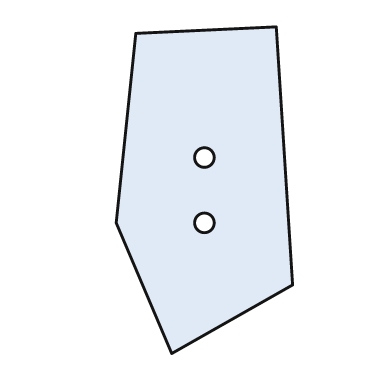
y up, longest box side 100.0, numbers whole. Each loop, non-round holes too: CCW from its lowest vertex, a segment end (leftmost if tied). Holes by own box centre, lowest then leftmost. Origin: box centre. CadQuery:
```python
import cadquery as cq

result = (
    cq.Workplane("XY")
    .moveTo(-10.0, -50.0)
    .lineTo(27.0, -29.0)
    .lineTo(22.0, 50.0)
    .lineTo(-21.0, 48.0)
    .lineTo(-27.0, -10.0)
    .close()
    .moveTo(0.0, -10.0)
    .circle(3.0)
    .moveTo(0.0, 10.0)
    .circle(3.0)
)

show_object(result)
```